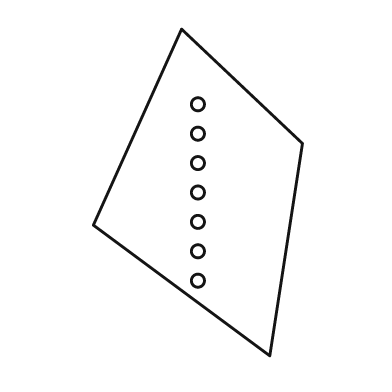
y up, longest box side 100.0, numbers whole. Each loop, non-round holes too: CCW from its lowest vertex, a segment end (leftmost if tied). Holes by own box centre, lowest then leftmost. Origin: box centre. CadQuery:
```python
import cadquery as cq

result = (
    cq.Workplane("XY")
    .moveTo(22.0, -50.0)
    .lineTo(32.0, 15.0)
    .lineTo(-5.0, 50.0)
    .lineTo(-32.0, -10.0)
    .close()
    .moveTo(0.0, -27.0)
    .circle(2.0)
    .moveTo(0.0, -18.0)
    .circle(2.0)
    .moveTo(0.0, -9.0)
    .circle(2.0)
    .moveTo(0.0, 0.0)
    .circle(2.0)
    .moveTo(0.0, 9.0)
    .circle(2.0)
    .moveTo(0.0, 18.0)
    .circle(2.0)
    .moveTo(0.0, 27.0)
    .circle(2.0)
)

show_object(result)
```